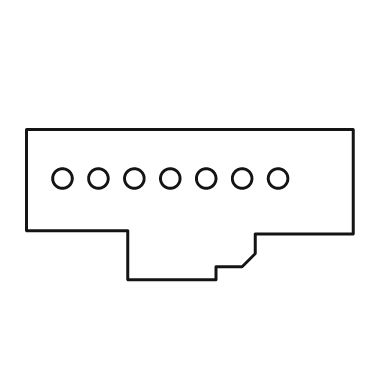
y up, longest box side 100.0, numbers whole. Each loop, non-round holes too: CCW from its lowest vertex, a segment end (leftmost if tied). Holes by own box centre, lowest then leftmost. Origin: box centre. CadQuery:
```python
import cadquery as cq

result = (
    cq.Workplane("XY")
    .moveTo(-19.0, -23.0)
    .lineTo(8.0, -23.0)
    .lineTo(8.0, -19.0)
    .lineTo(16.0, -19.0)
    .lineTo(20.0, -15.0)
    .lineTo(20.0, -9.0)
    .lineTo(50.0, -9.0)
    .lineTo(50.0, 23.0)
    .lineTo(-50.0, 23.0)
    .lineTo(-50.0, -8.0)
    .lineTo(-19.0, -8.0)
    .close()
    .moveTo(-39.0, 8.0)
    .circle(3.0)
    .moveTo(-28.0, 8.0)
    .circle(3.0)
    .moveTo(-17.0, 8.0)
    .circle(3.0)
    .moveTo(-6.0, 8.0)
    .circle(3.0)
    .moveTo(5.0, 8.0)
    .circle(3.0)
    .moveTo(16.0, 8.0)
    .circle(3.0)
    .moveTo(27.0, 8.0)
    .circle(3.0)
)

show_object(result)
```